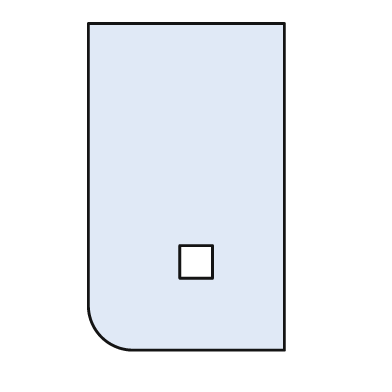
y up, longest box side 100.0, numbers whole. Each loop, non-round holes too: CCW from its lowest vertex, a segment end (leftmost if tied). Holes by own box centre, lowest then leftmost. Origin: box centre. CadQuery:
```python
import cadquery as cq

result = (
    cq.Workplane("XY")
    .moveTo(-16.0, -50.0)
    .lineTo(30.0, -50.0)
    .lineTo(30.0, 50.0)
    .lineTo(-30.0, 50.0)
    .lineTo(-30.0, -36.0)
    .threePointArc((-26.0, -46.0), (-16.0, -50.0))
    .close()
    .moveTo(-2.0, -28.0)
    .lineTo(8.0, -28.0)
    .lineTo(8.0, -18.0)
    .lineTo(-2.0, -18.0)
    .close()
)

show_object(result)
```